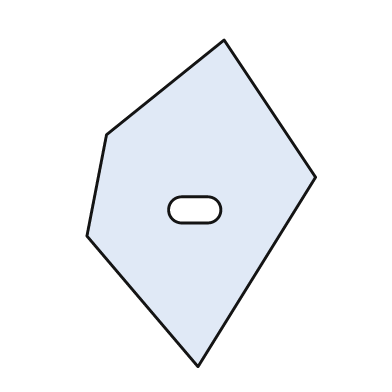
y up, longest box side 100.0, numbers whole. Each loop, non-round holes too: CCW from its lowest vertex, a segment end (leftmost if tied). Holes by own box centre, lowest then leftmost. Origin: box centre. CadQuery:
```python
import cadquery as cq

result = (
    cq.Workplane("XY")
    .moveTo(-1.0, -50.0)
    .lineTo(35.0, 8.0)
    .lineTo(7.0, 50.0)
    .lineTo(-29.0, 21.0)
    .lineTo(-35.0, -10.0)
    .close()
    .moveTo(-6.0, -6.0)
    .lineTo(2.0, -6.0)
    .threePointArc((6.0, -2.0), (2.0, 2.0))
    .lineTo(-6.0, 2.0)
    .threePointArc((-10.0, -2.0), (-6.0, -6.0))
    .close()
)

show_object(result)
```